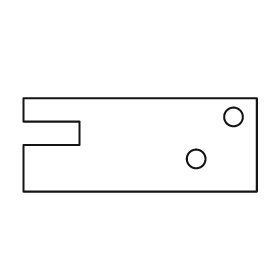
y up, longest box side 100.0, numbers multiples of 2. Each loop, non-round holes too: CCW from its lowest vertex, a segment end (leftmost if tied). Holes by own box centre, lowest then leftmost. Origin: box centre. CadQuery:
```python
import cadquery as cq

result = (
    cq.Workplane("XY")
    .moveTo(-50.0, -20.0)
    .lineTo(50.0, -20.0)
    .lineTo(50.0, 20.0)
    .lineTo(-50.0, 20.0)
    .lineTo(-50.0, 10.0)
    .lineTo(-26.0, 10.0)
    .lineTo(-26.0, 0.0)
    .lineTo(-50.0, 0.0)
    .close()
    .moveTo(24.0, -6.0)
    .circle(4.0)
    .moveTo(40.0, 12.0)
    .circle(4.0)
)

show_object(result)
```